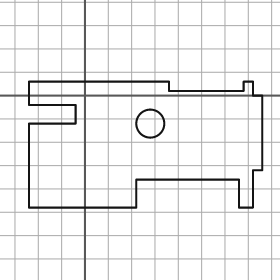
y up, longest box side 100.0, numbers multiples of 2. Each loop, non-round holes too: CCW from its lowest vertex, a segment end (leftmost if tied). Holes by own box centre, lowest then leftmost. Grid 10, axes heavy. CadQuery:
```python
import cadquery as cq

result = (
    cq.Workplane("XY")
    .moveTo(-24.0, -48.0)
    .lineTo(22.0, -48.0)
    .lineTo(22.0, -36.0)
    .lineTo(66.0, -36.0)
    .lineTo(66.0, -48.0)
    .lineTo(72.0, -48.0)
    .lineTo(72.0, -32.0)
    .lineTo(76.0, -32.0)
    .lineTo(76.0, 0.0)
    .lineTo(72.0, 0.0)
    .lineTo(72.0, 6.0)
    .lineTo(68.0, 6.0)
    .lineTo(68.0, 2.0)
    .lineTo(36.0, 2.0)
    .lineTo(36.0, 6.0)
    .lineTo(-24.0, 6.0)
    .lineTo(-24.0, -4.0)
    .lineTo(-4.0, -4.0)
    .lineTo(-4.0, -12.0)
    .lineTo(-24.0, -12.0)
    .close()
    .moveTo(28.0, -12.0)
    .circle(6.0)
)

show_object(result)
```